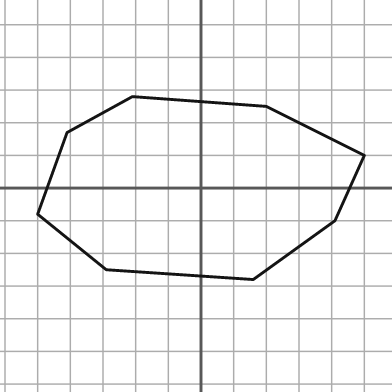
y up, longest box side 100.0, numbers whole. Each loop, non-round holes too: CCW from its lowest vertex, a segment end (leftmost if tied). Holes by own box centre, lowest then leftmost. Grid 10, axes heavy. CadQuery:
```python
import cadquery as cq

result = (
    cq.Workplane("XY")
    .moveTo(16.0, -28.0)
    .lineTo(41.0, -10.0)
    .lineTo(50.0, 10.0)
    .lineTo(20.0, 25.0)
    .lineTo(-21.0, 28.0)
    .lineTo(-41.0, 17.0)
    .lineTo(-50.0, -8.0)
    .lineTo(-29.0, -25.0)
    .close()
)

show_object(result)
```